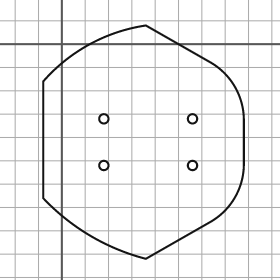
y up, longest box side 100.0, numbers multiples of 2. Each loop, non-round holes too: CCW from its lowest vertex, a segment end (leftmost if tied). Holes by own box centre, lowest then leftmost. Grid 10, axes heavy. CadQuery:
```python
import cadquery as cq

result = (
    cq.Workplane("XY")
    .moveTo(36.0, -92.0)
    .lineTo(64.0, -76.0)
    .threePointArc((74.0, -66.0), (78.0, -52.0))
    .lineTo(78.0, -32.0)
    .threePointArc((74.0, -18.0), (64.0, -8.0))
    .lineTo(36.0, 8.0)
    .threePointArc((12.0, 0.0), (-8.0, -16.0))
    .lineTo(-8.0, -66.0)
    .threePointArc((12.0, -82.0), (36.0, -92.0))
    .close()
    .moveTo(18.0, -52.0)
    .circle(2.0)
    .moveTo(56.0, -52.0)
    .circle(2.0)
    .moveTo(18.0, -32.0)
    .circle(2.0)
    .moveTo(56.0, -32.0)
    .circle(2.0)
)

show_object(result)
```